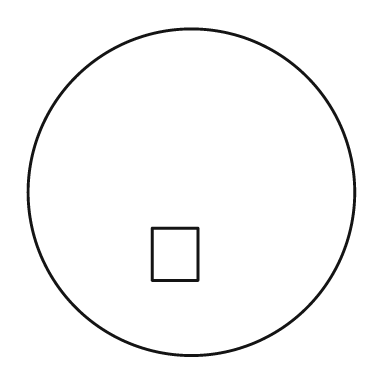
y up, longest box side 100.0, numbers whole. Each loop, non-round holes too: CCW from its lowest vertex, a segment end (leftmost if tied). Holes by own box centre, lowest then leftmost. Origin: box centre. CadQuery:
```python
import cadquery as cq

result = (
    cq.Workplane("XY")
    .moveTo(0.0, 0.0)
    .circle(50.0)
    .moveTo(-12.0, -27.0)
    .lineTo(2.0, -27.0)
    .lineTo(2.0, -11.0)
    .lineTo(-12.0, -11.0)
    .close()
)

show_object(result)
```